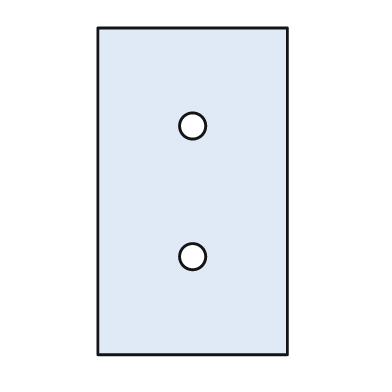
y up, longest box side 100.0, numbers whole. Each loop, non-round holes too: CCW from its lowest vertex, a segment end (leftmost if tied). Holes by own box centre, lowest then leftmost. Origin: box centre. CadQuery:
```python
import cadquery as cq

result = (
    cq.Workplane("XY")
    .moveTo(-29.0, -50.0)
    .lineTo(29.0, -50.0)
    .lineTo(29.0, 50.0)
    .lineTo(-29.0, 50.0)
    .close()
    .moveTo(0.0, -20.0)
    .circle(4.0)
    .moveTo(0.0, 20.0)
    .circle(4.0)
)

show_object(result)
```